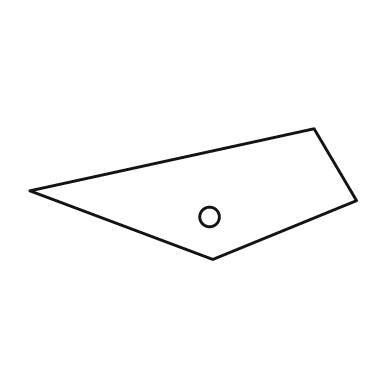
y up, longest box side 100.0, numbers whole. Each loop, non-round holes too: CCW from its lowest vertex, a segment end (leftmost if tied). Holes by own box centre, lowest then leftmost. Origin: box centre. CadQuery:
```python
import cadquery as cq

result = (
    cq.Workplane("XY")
    .moveTo(6.0, -20.0)
    .lineTo(50.0, -2.0)
    .lineTo(37.0, 20.0)
    .lineTo(-50.0, 1.0)
    .close()
    .moveTo(5.0, -7.0)
    .circle(3.0)
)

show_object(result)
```